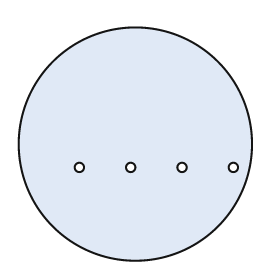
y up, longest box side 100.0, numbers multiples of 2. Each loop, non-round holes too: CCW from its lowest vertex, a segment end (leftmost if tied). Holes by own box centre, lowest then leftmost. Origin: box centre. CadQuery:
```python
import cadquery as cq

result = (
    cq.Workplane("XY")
    .moveTo(0.0, 0.0)
    .circle(50.0)
    .moveTo(-24.0, -10.0)
    .circle(2.0)
    .moveTo(-2.0, -10.0)
    .circle(2.0)
    .moveTo(20.0, -10.0)
    .circle(2.0)
    .moveTo(42.0, -10.0)
    .circle(2.0)
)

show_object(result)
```